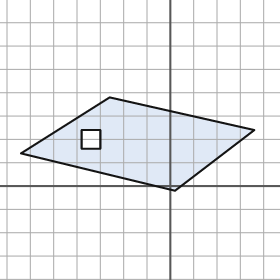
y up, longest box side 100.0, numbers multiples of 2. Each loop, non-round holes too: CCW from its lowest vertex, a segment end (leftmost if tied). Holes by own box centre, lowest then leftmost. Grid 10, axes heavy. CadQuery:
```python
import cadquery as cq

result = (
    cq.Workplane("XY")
    .moveTo(2.0, -2.0)
    .lineTo(36.0, 24.0)
    .lineTo(-26.0, 38.0)
    .lineTo(-64.0, 14.0)
    .close()
    .moveTo(-38.0, 16.0)
    .lineTo(-30.0, 16.0)
    .lineTo(-30.0, 24.0)
    .lineTo(-38.0, 24.0)
    .close()
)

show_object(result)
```